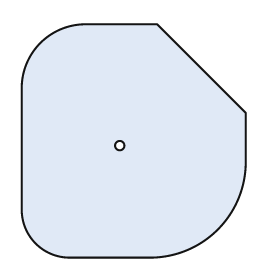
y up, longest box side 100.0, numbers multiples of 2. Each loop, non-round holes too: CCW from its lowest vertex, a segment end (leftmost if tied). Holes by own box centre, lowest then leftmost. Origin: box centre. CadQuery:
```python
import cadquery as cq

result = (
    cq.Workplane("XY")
    .moveTo(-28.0, -50.0)
    .lineTo(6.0, -50.0)
    .threePointArc((36.0, -38.0), (48.0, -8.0))
    .lineTo(48.0, 12.0)
    .lineTo(10.0, 50.0)
    .lineTo(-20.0, 50.0)
    .threePointArc((-40.0, 42.0), (-48.0, 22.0))
    .lineTo(-48.0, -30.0)
    .threePointArc((-42.0, -44.0), (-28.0, -50.0))
    .close()
    .moveTo(-6.0, -2.0)
    .circle(2.0)
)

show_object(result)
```